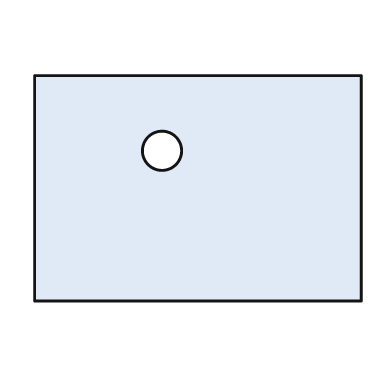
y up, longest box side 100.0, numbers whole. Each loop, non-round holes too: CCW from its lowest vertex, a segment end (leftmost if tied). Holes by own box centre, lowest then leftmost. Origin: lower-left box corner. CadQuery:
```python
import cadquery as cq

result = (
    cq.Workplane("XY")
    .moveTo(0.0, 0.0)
    .lineTo(100.0, 0.0)
    .lineTo(100.0, 69.0)
    .lineTo(0.0, 69.0)
    .close()
    .moveTo(39.0, 46.0)
    .circle(6.0)
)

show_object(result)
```